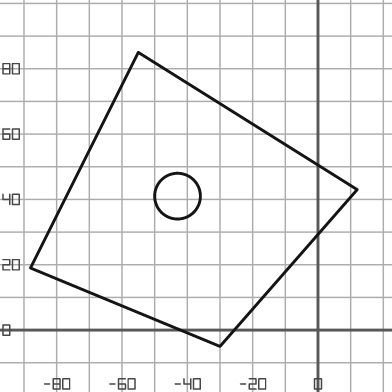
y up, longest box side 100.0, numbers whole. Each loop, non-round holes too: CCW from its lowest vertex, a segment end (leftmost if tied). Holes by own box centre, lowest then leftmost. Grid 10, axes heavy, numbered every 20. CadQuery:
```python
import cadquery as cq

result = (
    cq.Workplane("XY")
    .moveTo(-30.0, -5.0)
    .lineTo(12.0, 43.0)
    .lineTo(-55.0, 85.0)
    .lineTo(-88.0, 19.0)
    .close()
    .moveTo(-43.0, 41.0)
    .circle(7.0)
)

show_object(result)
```